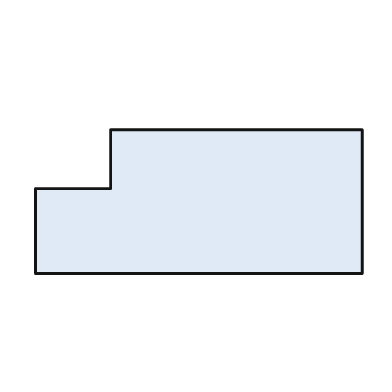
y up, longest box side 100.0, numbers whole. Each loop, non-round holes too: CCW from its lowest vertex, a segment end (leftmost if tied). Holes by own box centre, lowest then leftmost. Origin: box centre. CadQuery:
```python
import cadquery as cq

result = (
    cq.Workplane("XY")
    .moveTo(-50.0, -22.0)
    .lineTo(50.0, -22.0)
    .lineTo(50.0, 22.0)
    .lineTo(-27.0, 22.0)
    .lineTo(-27.0, 4.0)
    .lineTo(-50.0, 4.0)
    .close()
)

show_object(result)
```